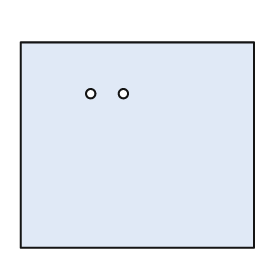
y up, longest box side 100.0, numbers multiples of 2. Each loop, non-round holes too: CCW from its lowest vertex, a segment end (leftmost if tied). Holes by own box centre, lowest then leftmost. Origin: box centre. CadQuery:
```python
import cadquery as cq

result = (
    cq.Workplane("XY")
    .moveTo(-50.0, -44.0)
    .lineTo(50.0, -44.0)
    .lineTo(50.0, 44.0)
    .lineTo(-50.0, 44.0)
    .close()
    .moveTo(-20.0, 22.0)
    .circle(2.0)
    .moveTo(-6.0, 22.0)
    .circle(2.0)
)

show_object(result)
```